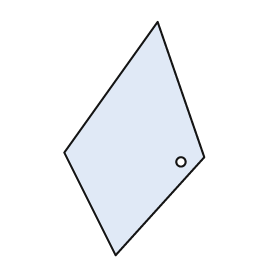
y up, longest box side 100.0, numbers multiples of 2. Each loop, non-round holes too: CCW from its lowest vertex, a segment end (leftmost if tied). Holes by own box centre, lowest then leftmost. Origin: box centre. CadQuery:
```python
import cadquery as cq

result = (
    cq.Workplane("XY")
    .moveTo(-8.0, -50.0)
    .lineTo(30.0, -8.0)
    .lineTo(10.0, 50.0)
    .lineTo(-30.0, -6.0)
    .close()
    .moveTo(20.0, -10.0)
    .circle(2.0)
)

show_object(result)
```